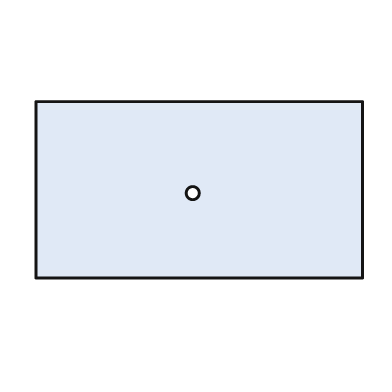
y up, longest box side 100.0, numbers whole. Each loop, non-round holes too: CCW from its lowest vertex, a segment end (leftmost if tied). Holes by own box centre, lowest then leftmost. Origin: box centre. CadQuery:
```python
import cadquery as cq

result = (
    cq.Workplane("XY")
    .moveTo(-50.0, -27.0)
    .lineTo(50.0, -27.0)
    .lineTo(50.0, 27.0)
    .lineTo(-50.0, 27.0)
    .close()
    .moveTo(-2.0, -1.0)
    .circle(2.0)
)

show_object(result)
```